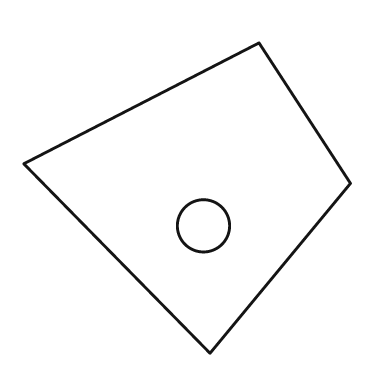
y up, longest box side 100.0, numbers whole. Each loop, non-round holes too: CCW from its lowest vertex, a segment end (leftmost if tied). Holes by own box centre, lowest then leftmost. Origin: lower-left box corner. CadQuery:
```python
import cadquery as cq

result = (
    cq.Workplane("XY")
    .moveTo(57.0, 0.0)
    .lineTo(100.0, 52.0)
    .lineTo(72.0, 95.0)
    .lineTo(0.0, 58.0)
    .close()
    .moveTo(55.0, 39.0)
    .circle(8.0)
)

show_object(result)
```